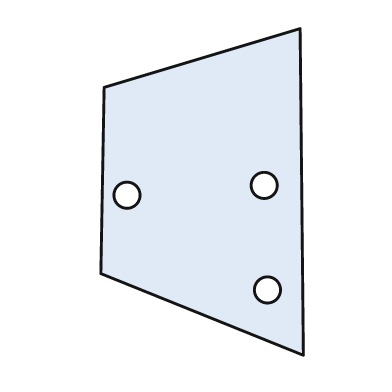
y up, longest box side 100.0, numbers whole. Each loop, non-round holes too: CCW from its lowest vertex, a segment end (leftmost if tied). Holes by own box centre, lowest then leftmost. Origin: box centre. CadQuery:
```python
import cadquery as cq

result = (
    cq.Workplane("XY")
    .moveTo(31.0, -50.0)
    .lineTo(30.0, 50.0)
    .lineTo(-30.0, 32.0)
    .lineTo(-31.0, -25.0)
    .close()
    .moveTo(20.0, -30.0)
    .circle(4.0)
    .moveTo(-23.0, -1.0)
    .circle(4.0)
    .moveTo(19.0, 2.0)
    .circle(4.0)
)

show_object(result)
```